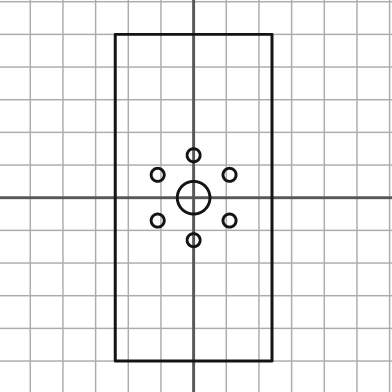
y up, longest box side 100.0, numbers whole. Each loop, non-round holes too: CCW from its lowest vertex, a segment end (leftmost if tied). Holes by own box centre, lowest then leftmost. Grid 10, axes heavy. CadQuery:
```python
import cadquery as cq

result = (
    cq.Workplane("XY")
    .moveTo(-24.0, -50.0)
    .lineTo(24.0, -50.0)
    .lineTo(24.0, 50.0)
    .lineTo(-24.0, 50.0)
    .close()
    .moveTo(0.0, -13.0)
    .circle(2.0)
    .moveTo(-11.0, -7.0)
    .circle(2.0)
    .moveTo(11.0, -7.0)
    .circle(2.0)
    .moveTo(0.0, 0.0)
    .circle(5.0)
    .moveTo(-11.0, 7.0)
    .circle(2.0)
    .moveTo(11.0, 7.0)
    .circle(2.0)
    .moveTo(0.0, 13.0)
    .circle(2.0)
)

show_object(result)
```